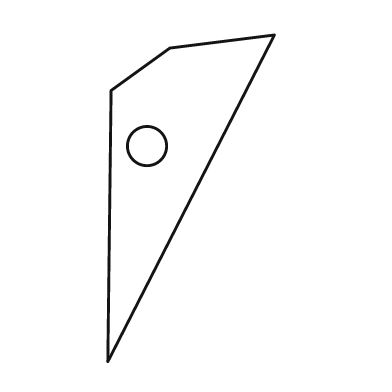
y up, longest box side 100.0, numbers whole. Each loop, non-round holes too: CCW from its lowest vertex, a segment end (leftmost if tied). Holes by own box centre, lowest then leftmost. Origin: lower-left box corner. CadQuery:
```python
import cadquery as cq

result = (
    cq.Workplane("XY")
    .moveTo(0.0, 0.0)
    .lineTo(51.0, 100.0)
    .lineTo(19.0, 96.0)
    .lineTo(1.0, 83.0)
    .close()
    .moveTo(12.0, 66.0)
    .circle(6.0)
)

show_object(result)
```